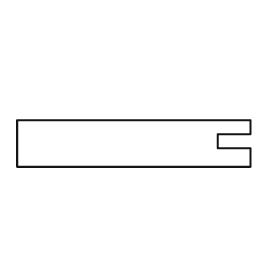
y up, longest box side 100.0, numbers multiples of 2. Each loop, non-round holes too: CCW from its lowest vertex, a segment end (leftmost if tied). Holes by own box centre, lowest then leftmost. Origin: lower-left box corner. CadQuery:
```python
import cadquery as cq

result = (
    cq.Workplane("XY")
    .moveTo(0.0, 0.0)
    .lineTo(100.0, 0.0)
    .lineTo(100.0, 8.0)
    .lineTo(86.0, 8.0)
    .lineTo(86.0, 14.0)
    .lineTo(100.0, 14.0)
    .lineTo(100.0, 20.0)
    .lineTo(0.0, 20.0)
    .close()
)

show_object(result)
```